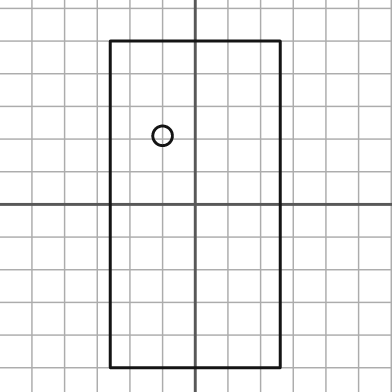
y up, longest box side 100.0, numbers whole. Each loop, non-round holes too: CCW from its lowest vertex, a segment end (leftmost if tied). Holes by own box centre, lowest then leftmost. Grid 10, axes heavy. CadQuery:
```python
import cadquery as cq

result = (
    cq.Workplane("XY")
    .moveTo(-26.0, -50.0)
    .lineTo(26.0, -50.0)
    .lineTo(26.0, 50.0)
    .lineTo(-26.0, 50.0)
    .close()
    .moveTo(-10.0, 21.0)
    .circle(3.0)
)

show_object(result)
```